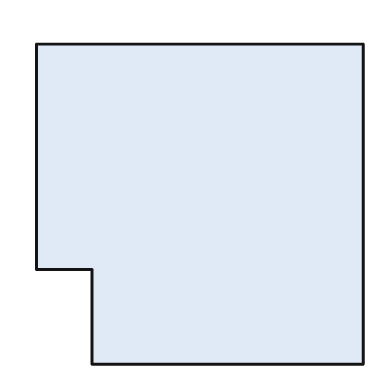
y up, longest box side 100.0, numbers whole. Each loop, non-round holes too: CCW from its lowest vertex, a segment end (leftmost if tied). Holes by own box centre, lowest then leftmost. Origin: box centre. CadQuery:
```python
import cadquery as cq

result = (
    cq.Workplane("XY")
    .moveTo(-33.0, -49.0)
    .lineTo(50.0, -49.0)
    .lineTo(50.0, 49.0)
    .lineTo(-50.0, 49.0)
    .lineTo(-50.0, -20.0)
    .lineTo(-33.0, -20.0)
    .close()
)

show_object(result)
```